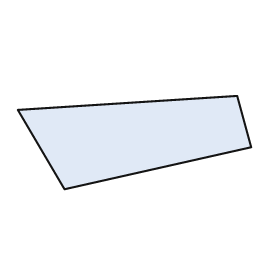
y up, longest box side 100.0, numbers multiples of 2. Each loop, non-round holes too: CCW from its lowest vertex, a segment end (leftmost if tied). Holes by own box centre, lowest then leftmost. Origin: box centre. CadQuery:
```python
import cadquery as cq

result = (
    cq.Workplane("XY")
    .moveTo(-30.0, -20.0)
    .lineTo(50.0, -2.0)
    .lineTo(44.0, 20.0)
    .lineTo(-50.0, 14.0)
    .close()
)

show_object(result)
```